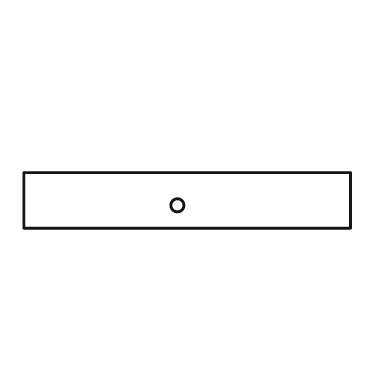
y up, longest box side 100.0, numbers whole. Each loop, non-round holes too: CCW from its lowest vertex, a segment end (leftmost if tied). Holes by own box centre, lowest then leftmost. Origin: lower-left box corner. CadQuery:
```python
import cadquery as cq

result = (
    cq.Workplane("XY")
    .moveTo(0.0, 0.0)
    .lineTo(100.0, 0.0)
    .lineTo(100.0, 17.0)
    .lineTo(0.0, 17.0)
    .close()
    .moveTo(47.0, 7.0)
    .circle(2.0)
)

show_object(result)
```